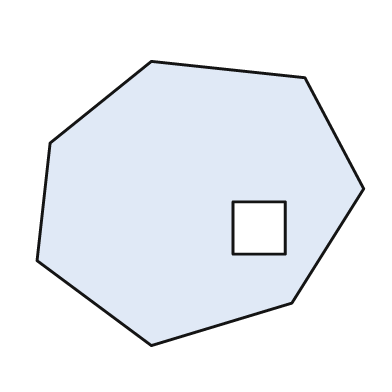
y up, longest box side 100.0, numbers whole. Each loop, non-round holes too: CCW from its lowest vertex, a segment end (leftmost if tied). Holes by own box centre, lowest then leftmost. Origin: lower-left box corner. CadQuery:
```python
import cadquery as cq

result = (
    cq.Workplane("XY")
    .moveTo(35.0, 0.0)
    .lineTo(78.0, 13.0)
    .lineTo(100.0, 48.0)
    .lineTo(82.0, 82.0)
    .lineTo(35.0, 87.0)
    .lineTo(4.0, 62.0)
    .lineTo(0.0, 26.0)
    .close()
    .moveTo(60.0, 28.0)
    .lineTo(76.0, 28.0)
    .lineTo(76.0, 44.0)
    .lineTo(60.0, 44.0)
    .close()
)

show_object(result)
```